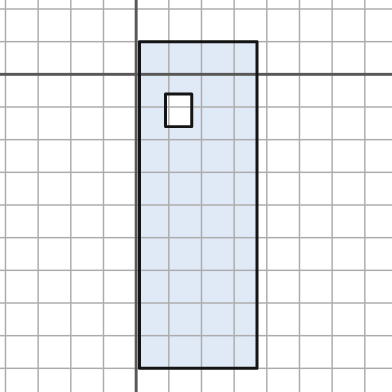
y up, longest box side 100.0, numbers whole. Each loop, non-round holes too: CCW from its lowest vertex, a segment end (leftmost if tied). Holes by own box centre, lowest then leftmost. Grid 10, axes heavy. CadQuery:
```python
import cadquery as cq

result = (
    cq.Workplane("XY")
    .moveTo(1.0, -90.0)
    .lineTo(37.0, -90.0)
    .lineTo(37.0, 10.0)
    .lineTo(1.0, 10.0)
    .close()
    .moveTo(9.0, -16.0)
    .lineTo(17.0, -16.0)
    .lineTo(17.0, -6.0)
    .lineTo(9.0, -6.0)
    .close()
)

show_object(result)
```